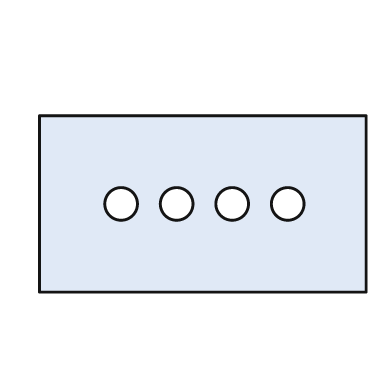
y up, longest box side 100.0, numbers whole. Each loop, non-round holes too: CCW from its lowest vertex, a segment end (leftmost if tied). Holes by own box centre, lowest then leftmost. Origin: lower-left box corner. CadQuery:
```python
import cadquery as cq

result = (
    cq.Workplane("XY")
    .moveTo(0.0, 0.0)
    .lineTo(100.0, 0.0)
    .lineTo(100.0, 54.0)
    .lineTo(0.0, 54.0)
    .close()
    .moveTo(25.0, 27.0)
    .circle(5.0)
    .moveTo(42.0, 27.0)
    .circle(5.0)
    .moveTo(59.0, 27.0)
    .circle(5.0)
    .moveTo(76.0, 27.0)
    .circle(5.0)
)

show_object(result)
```